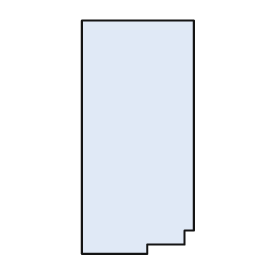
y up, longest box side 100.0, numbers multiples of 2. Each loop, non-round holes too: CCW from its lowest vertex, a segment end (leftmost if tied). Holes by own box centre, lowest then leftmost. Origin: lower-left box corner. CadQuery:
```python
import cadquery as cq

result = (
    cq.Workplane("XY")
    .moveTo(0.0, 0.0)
    .lineTo(28.0, 0.0)
    .lineTo(28.0, 4.0)
    .lineTo(44.0, 4.0)
    .lineTo(44.0, 10.0)
    .lineTo(48.0, 10.0)
    .lineTo(48.0, 100.0)
    .lineTo(0.0, 100.0)
    .close()
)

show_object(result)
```